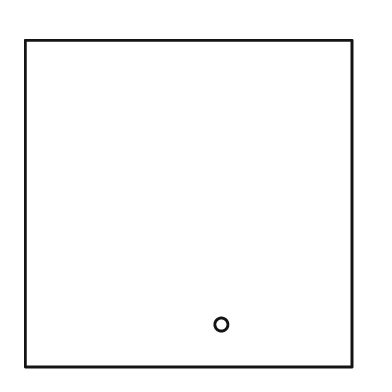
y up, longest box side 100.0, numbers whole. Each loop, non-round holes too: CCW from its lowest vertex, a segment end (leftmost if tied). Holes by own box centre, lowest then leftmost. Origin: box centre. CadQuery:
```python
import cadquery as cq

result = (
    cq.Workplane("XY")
    .moveTo(-50.0, -50.0)
    .lineTo(50.0, -50.0)
    .lineTo(50.0, 50.0)
    .lineTo(-50.0, 50.0)
    .close()
    .moveTo(10.0, -37.0)
    .circle(2.0)
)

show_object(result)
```